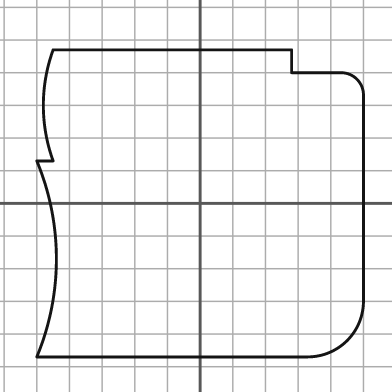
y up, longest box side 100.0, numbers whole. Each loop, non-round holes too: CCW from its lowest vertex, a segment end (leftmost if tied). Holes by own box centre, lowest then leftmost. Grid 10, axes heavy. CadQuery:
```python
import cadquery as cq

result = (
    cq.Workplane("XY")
    .moveTo(-50.0, -47.0)
    .lineTo(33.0, -47.0)
    .threePointArc((45.0, -42.0), (50.0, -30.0))
    .lineTo(50.0, 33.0)
    .threePointArc((48.0, 38.0), (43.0, 40.0))
    .lineTo(28.0, 40.0)
    .lineTo(28.0, 47.0)
    .lineTo(-45.0, 47.0)
    .threePointArc((-48.0, 30.0), (-45.0, 13.0))
    .lineTo(-50.0, 13.0)
    .threePointArc((-44.0, -17.0), (-50.0, -47.0))
    .close()
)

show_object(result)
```